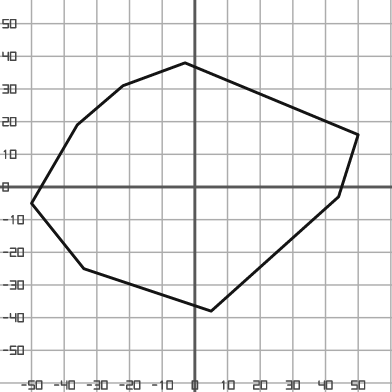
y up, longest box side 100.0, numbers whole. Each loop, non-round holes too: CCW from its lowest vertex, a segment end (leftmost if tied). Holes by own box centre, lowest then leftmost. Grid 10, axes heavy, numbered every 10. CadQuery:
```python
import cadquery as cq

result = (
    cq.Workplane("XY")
    .moveTo(5.0, -38.0)
    .lineTo(44.0, -3.0)
    .lineTo(50.0, 16.0)
    .lineTo(-3.0, 38.0)
    .lineTo(-22.0, 31.0)
    .lineTo(-36.0, 19.0)
    .lineTo(-50.0, -5.0)
    .lineTo(-34.0, -25.0)
    .close()
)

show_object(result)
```